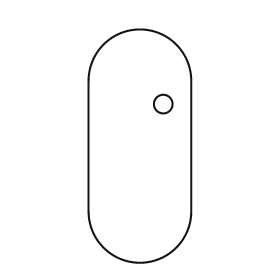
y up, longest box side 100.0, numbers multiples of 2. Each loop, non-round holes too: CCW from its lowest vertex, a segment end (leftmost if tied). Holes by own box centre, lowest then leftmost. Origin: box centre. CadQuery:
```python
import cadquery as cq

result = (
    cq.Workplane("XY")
    .moveTo(-22.0, -28.0)
    .threePointArc((0.0, -50.0), (22.0, -28.0))
    .lineTo(22.0, 28.0)
    .threePointArc((0.0, 50.0), (-22.0, 28.0))
    .close()
    .moveTo(10.0, 18.0)
    .circle(4.0)
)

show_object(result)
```